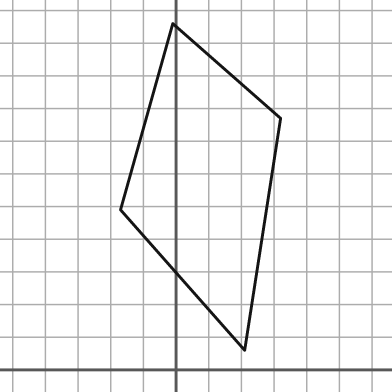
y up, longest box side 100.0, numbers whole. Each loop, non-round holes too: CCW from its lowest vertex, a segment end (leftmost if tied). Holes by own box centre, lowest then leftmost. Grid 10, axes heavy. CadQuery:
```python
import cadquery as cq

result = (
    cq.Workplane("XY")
    .moveTo(21.0, 6.0)
    .lineTo(32.0, 77.0)
    .lineTo(-1.0, 106.0)
    .lineTo(-17.0, 49.0)
    .close()
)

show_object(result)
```